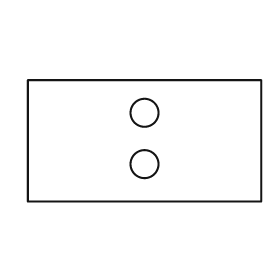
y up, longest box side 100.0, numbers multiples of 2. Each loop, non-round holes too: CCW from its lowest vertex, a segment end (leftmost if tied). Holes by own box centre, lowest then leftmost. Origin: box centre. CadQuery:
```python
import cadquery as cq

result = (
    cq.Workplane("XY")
    .moveTo(-50.0, -26.0)
    .lineTo(50.0, -26.0)
    .lineTo(50.0, 26.0)
    .lineTo(-50.0, 26.0)
    .close()
    .moveTo(0.0, -10.0)
    .circle(6.0)
    .moveTo(0.0, 12.0)
    .circle(6.0)
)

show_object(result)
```